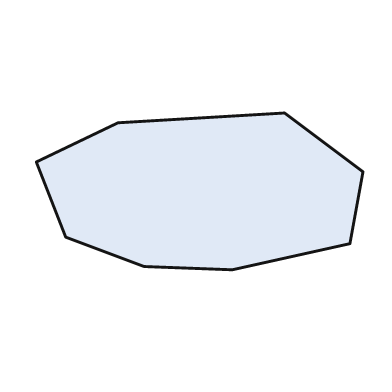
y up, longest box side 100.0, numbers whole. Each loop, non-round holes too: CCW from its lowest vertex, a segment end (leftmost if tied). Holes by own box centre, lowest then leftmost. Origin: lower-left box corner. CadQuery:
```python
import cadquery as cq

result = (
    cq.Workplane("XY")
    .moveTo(60.0, 0.0)
    .lineTo(96.0, 8.0)
    .lineTo(100.0, 30.0)
    .lineTo(76.0, 48.0)
    .lineTo(25.0, 45.0)
    .lineTo(0.0, 33.0)
    .lineTo(9.0, 10.0)
    .lineTo(33.0, 1.0)
    .close()
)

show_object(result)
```